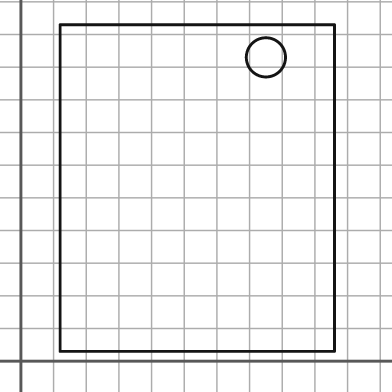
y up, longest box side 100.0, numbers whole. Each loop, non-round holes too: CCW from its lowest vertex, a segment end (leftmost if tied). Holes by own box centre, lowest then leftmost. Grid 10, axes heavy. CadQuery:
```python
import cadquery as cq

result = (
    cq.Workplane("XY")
    .moveTo(12.0, 3.0)
    .lineTo(96.0, 3.0)
    .lineTo(96.0, 103.0)
    .lineTo(12.0, 103.0)
    .close()
    .moveTo(75.0, 93.0)
    .circle(6.0)
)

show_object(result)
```